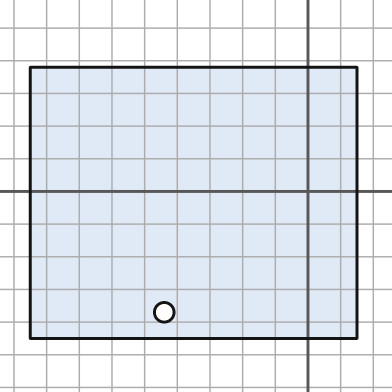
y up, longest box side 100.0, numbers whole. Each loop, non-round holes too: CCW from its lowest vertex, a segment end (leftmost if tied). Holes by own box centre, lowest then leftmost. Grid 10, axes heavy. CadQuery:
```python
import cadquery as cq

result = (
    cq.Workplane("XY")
    .moveTo(-85.0, -45.0)
    .lineTo(15.0, -45.0)
    .lineTo(15.0, 38.0)
    .lineTo(-85.0, 38.0)
    .close()
    .moveTo(-44.0, -37.0)
    .circle(3.0)
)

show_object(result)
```